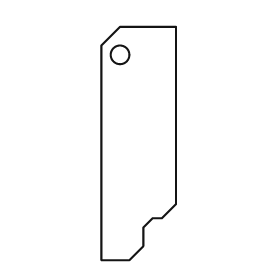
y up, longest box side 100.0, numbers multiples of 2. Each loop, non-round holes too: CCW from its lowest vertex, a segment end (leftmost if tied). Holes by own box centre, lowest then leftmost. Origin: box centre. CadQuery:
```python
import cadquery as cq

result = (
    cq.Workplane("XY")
    .moveTo(-16.0, -50.0)
    .lineTo(-4.0, -50.0)
    .lineTo(2.0, -44.0)
    .lineTo(2.0, -36.0)
    .lineTo(6.0, -32.0)
    .lineTo(10.0, -32.0)
    .lineTo(16.0, -26.0)
    .lineTo(16.0, 50.0)
    .lineTo(-8.0, 50.0)
    .lineTo(-16.0, 42.0)
    .close()
    .moveTo(-8.0, 38.0)
    .circle(4.0)
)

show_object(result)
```